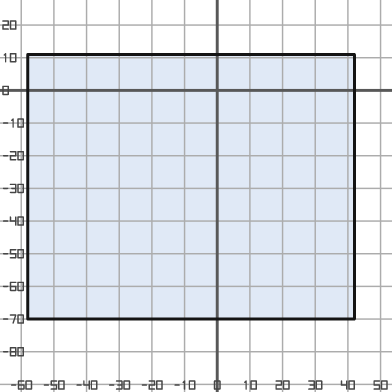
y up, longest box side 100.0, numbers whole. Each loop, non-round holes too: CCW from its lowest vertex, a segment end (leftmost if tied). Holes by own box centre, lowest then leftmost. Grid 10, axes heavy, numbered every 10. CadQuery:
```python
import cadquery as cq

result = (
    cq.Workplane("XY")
    .moveTo(-58.0, -70.0)
    .lineTo(42.0, -70.0)
    .lineTo(42.0, 11.0)
    .lineTo(-58.0, 11.0)
    .close()
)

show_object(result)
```